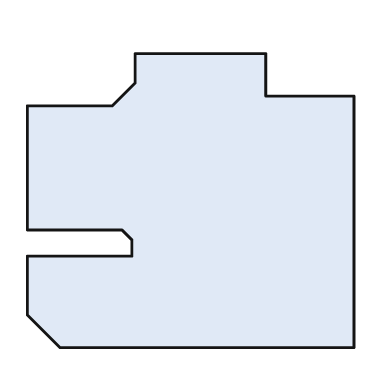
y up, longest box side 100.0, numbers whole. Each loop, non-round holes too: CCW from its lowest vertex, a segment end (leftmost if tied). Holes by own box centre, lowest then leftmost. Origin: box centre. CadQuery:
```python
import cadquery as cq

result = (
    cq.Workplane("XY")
    .moveTo(-40.0, -45.0)
    .lineTo(50.0, -45.0)
    .lineTo(50.0, 32.0)
    .lineTo(23.0, 32.0)
    .lineTo(23.0, 45.0)
    .lineTo(-17.0, 45.0)
    .lineTo(-17.0, 36.0)
    .lineTo(-24.0, 29.0)
    .lineTo(-50.0, 29.0)
    .lineTo(-50.0, -9.0)
    .lineTo(-21.0, -9.0)
    .lineTo(-18.0, -12.0)
    .lineTo(-18.0, -17.0)
    .lineTo(-50.0, -17.0)
    .lineTo(-50.0, -35.0)
    .close()
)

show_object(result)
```